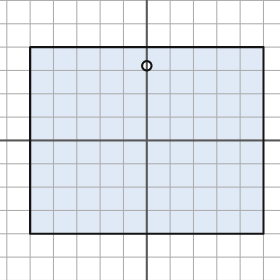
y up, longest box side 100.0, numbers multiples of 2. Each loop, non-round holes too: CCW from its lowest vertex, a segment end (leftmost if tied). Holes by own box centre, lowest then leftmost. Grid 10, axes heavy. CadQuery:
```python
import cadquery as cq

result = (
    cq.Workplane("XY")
    .moveTo(-50.0, -40.0)
    .lineTo(50.0, -40.0)
    .lineTo(50.0, 40.0)
    .lineTo(-50.0, 40.0)
    .close()
    .moveTo(0.0, 32.0)
    .circle(2.0)
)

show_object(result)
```